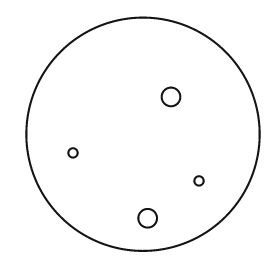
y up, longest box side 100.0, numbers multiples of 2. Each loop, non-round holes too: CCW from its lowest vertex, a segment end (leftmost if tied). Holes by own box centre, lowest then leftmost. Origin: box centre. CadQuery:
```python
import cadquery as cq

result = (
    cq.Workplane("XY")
    .moveTo(0.0, 0.0)
    .circle(50.0)
    .moveTo(2.0, -36.0)
    .circle(4.0)
    .moveTo(24.0, -20.0)
    .circle(2.0)
    .moveTo(-30.0, -8.0)
    .circle(2.0)
    .moveTo(12.0, 16.0)
    .circle(4.0)
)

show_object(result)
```